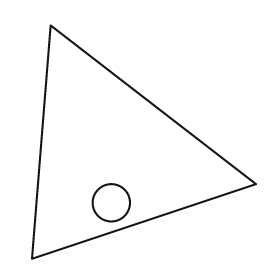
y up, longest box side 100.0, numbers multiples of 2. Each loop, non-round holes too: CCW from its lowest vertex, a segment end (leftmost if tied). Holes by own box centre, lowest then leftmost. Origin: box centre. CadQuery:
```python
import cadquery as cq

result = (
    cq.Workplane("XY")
    .moveTo(-48.0, -50.0)
    .lineTo(48.0, -18.0)
    .lineTo(-40.0, 50.0)
    .close()
    .moveTo(-14.0, -26.0)
    .circle(8.0)
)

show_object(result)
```